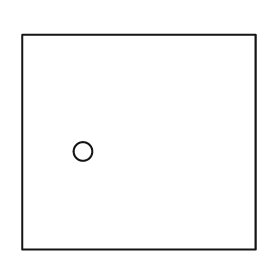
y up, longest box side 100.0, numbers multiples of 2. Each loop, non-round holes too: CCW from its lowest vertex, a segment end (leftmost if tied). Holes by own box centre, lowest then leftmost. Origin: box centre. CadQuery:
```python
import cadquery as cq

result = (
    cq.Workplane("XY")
    .moveTo(-50.0, -46.0)
    .lineTo(50.0, -46.0)
    .lineTo(50.0, 46.0)
    .lineTo(-50.0, 46.0)
    .close()
    .moveTo(-24.0, -4.0)
    .circle(4.0)
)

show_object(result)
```